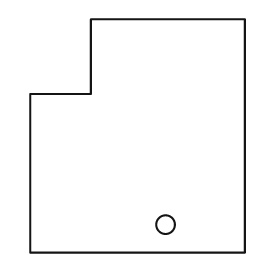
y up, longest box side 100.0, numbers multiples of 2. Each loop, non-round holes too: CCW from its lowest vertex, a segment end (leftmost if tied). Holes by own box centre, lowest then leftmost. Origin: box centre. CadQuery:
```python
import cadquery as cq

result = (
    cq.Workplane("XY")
    .moveTo(-46.0, -50.0)
    .lineTo(46.0, -50.0)
    .lineTo(46.0, 50.0)
    .lineTo(-20.0, 50.0)
    .lineTo(-20.0, 18.0)
    .lineTo(-46.0, 18.0)
    .close()
    .moveTo(12.0, -38.0)
    .circle(4.0)
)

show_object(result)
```